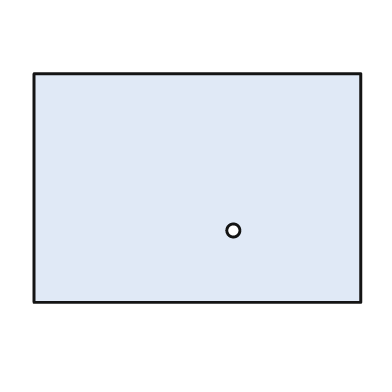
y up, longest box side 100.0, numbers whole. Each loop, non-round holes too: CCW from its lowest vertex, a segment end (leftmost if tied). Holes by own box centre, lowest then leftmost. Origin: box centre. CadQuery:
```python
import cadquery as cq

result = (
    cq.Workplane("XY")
    .moveTo(-50.0, -35.0)
    .lineTo(50.0, -35.0)
    .lineTo(50.0, 35.0)
    .lineTo(-50.0, 35.0)
    .close()
    .moveTo(11.0, -13.0)
    .circle(2.0)
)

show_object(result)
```